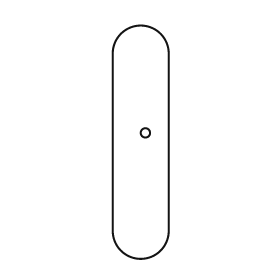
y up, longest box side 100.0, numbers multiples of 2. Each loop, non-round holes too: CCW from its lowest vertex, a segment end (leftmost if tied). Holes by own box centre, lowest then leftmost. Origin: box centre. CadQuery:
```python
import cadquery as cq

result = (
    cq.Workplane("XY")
    .moveTo(-12.0, -38.0)
    .threePointArc((0.0, -50.0), (12.0, -38.0))
    .lineTo(12.0, 38.0)
    .threePointArc((0.0, 50.0), (-12.0, 38.0))
    .close()
    .moveTo(2.0, 4.0)
    .circle(2.0)
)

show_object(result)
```